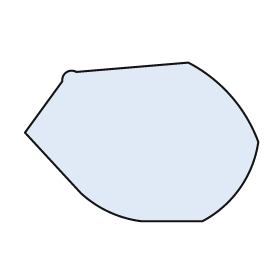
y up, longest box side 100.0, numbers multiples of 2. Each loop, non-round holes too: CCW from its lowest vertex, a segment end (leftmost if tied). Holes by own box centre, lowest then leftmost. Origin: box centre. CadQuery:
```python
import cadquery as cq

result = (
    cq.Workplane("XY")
    .moveTo(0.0, -34.0)
    .lineTo(26.0, -34.0)
    .threePointArc((42.0, -20.0), (50.0, 0.0))
    .threePointArc((38.0, 20.0), (20.0, 34.0))
    .lineTo(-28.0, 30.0)
    .threePointArc((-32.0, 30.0), (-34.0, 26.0))
    .lineTo(-50.0, 4.0)
    .lineTo(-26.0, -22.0)
    .threePointArc((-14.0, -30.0), (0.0, -34.0))
    .close()
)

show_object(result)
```